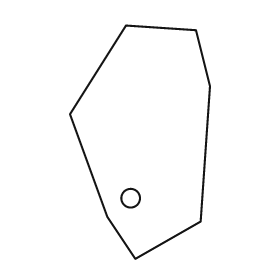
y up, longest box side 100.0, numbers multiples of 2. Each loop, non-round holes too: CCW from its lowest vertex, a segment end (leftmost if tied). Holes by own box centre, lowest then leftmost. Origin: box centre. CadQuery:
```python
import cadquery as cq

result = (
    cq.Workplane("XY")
    .moveTo(-2.0, -50.0)
    .lineTo(26.0, -34.0)
    .lineTo(30.0, 24.0)
    .lineTo(24.0, 48.0)
    .lineTo(-6.0, 50.0)
    .lineTo(-30.0, 12.0)
    .lineTo(-14.0, -32.0)
    .close()
    .moveTo(-4.0, -24.0)
    .circle(4.0)
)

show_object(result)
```